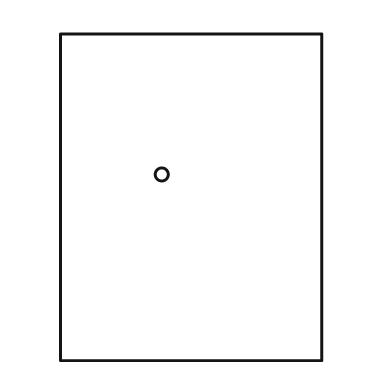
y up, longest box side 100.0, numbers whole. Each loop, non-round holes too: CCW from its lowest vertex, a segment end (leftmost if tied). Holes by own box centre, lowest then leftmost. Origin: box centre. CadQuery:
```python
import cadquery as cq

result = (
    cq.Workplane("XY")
    .moveTo(-40.0, -50.0)
    .lineTo(40.0, -50.0)
    .lineTo(40.0, 50.0)
    .lineTo(-40.0, 50.0)
    .close()
    .moveTo(-9.0, 7.0)
    .circle(2.0)
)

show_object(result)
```